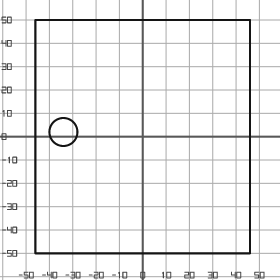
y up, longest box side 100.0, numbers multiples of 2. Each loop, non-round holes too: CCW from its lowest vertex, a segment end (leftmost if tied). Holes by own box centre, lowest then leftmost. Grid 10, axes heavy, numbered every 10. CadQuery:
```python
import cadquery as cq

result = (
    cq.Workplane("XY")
    .moveTo(-46.0, -50.0)
    .lineTo(46.0, -50.0)
    .lineTo(46.0, 50.0)
    .lineTo(-46.0, 50.0)
    .close()
    .moveTo(-34.0, 2.0)
    .circle(6.0)
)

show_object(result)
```